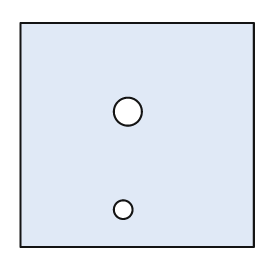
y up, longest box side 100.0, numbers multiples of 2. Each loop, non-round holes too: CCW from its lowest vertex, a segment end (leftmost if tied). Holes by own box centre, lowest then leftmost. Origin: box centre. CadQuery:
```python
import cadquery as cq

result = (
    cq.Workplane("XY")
    .moveTo(-50.0, -48.0)
    .lineTo(50.0, -48.0)
    .lineTo(50.0, 48.0)
    .lineTo(-50.0, 48.0)
    .close()
    .moveTo(-6.0, -32.0)
    .circle(4.0)
    .moveTo(-4.0, 10.0)
    .circle(6.0)
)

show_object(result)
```